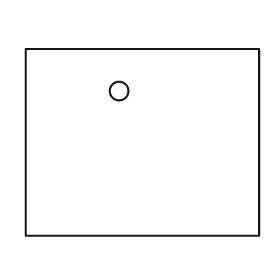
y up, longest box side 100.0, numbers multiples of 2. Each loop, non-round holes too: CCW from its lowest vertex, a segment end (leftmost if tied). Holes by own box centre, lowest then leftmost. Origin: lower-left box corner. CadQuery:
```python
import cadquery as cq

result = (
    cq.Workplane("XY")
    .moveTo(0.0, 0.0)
    .lineTo(100.0, 0.0)
    .lineTo(100.0, 80.0)
    .lineTo(0.0, 80.0)
    .close()
    .moveTo(40.0, 62.0)
    .circle(4.0)
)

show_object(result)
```